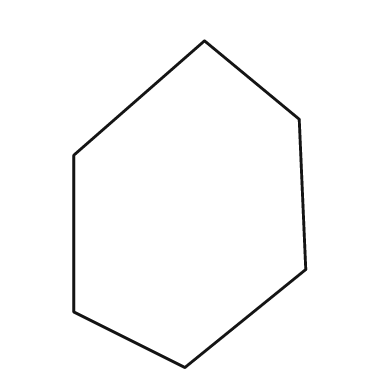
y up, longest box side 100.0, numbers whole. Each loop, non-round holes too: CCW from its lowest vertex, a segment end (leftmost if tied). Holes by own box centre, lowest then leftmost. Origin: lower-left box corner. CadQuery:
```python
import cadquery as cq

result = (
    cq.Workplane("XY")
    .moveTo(34.0, 0.0)
    .lineTo(71.0, 30.0)
    .lineTo(69.0, 76.0)
    .lineTo(40.0, 100.0)
    .lineTo(0.0, 65.0)
    .lineTo(0.0, 17.0)
    .close()
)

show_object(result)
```